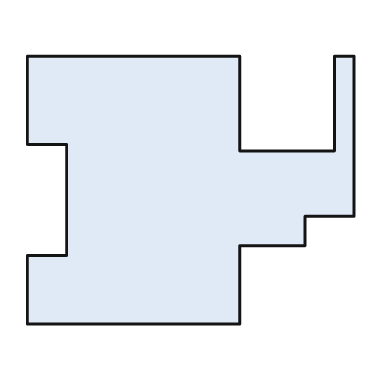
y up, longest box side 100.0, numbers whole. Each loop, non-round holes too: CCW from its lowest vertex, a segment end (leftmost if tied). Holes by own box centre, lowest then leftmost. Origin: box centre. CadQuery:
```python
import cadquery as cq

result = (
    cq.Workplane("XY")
    .moveTo(-50.0, -41.0)
    .lineTo(15.0, -41.0)
    .lineTo(15.0, -17.0)
    .lineTo(35.0, -17.0)
    .lineTo(35.0, -8.0)
    .lineTo(50.0, -8.0)
    .lineTo(50.0, 41.0)
    .lineTo(44.0, 41.0)
    .lineTo(44.0, 12.0)
    .lineTo(15.0, 12.0)
    .lineTo(15.0, 41.0)
    .lineTo(-50.0, 41.0)
    .lineTo(-50.0, 14.0)
    .lineTo(-38.0, 14.0)
    .lineTo(-38.0, -20.0)
    .lineTo(-50.0, -20.0)
    .close()
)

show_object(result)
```